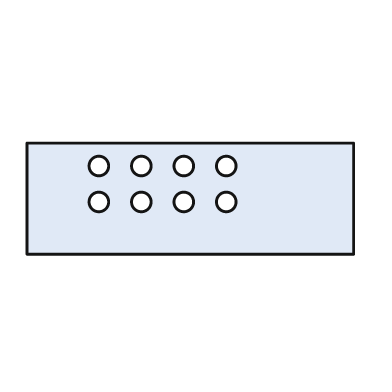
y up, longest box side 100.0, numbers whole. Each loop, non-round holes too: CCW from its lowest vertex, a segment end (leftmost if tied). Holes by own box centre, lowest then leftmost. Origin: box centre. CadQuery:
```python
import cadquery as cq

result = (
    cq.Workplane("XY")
    .moveTo(-50.0, -17.0)
    .lineTo(50.0, -17.0)
    .lineTo(50.0, 17.0)
    .lineTo(-50.0, 17.0)
    .close()
    .moveTo(-28.0, -1.0)
    .circle(3.0)
    .moveTo(-15.0, -1.0)
    .circle(3.0)
    .moveTo(-2.0, -1.0)
    .circle(3.0)
    .moveTo(11.0, -1.0)
    .circle(3.0)
    .moveTo(-28.0, 10.0)
    .circle(3.0)
    .moveTo(-15.0, 10.0)
    .circle(3.0)
    .moveTo(-2.0, 10.0)
    .circle(3.0)
    .moveTo(11.0, 10.0)
    .circle(3.0)
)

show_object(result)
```